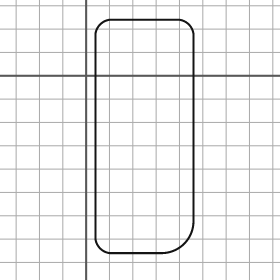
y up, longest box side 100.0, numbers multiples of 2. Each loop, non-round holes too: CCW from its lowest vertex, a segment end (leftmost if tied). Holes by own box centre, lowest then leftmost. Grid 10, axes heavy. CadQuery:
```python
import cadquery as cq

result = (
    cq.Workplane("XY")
    .moveTo(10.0, -76.0)
    .lineTo(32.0, -76.0)
    .threePointArc((42.0, -72.0), (46.0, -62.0))
    .lineTo(46.0, 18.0)
    .threePointArc((44.0, 22.0), (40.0, 24.0))
    .lineTo(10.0, 24.0)
    .threePointArc((6.0, 22.0), (4.0, 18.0))
    .lineTo(4.0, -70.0)
    .threePointArc((6.0, -74.0), (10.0, -76.0))
    .close()
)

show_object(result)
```